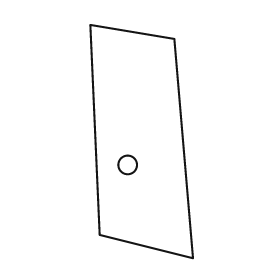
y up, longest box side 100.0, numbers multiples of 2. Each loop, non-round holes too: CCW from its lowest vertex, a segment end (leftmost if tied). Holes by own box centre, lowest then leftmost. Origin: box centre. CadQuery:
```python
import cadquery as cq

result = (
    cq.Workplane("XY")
    .moveTo(22.0, -50.0)
    .lineTo(14.0, 44.0)
    .lineTo(-22.0, 50.0)
    .lineTo(-18.0, -40.0)
    .close()
    .moveTo(-6.0, -10.0)
    .circle(4.0)
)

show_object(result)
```